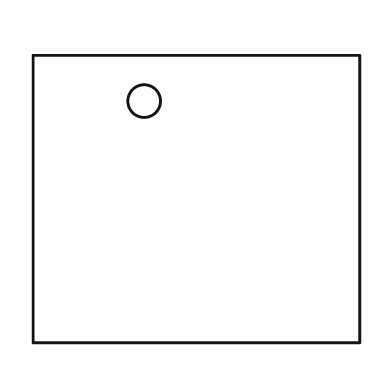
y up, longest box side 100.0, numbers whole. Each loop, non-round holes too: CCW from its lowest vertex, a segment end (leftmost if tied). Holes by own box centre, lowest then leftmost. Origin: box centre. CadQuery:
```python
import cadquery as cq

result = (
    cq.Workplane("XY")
    .moveTo(-50.0, -44.0)
    .lineTo(50.0, -44.0)
    .lineTo(50.0, 44.0)
    .lineTo(-50.0, 44.0)
    .close()
    .moveTo(-16.0, 30.0)
    .circle(5.0)
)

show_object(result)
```